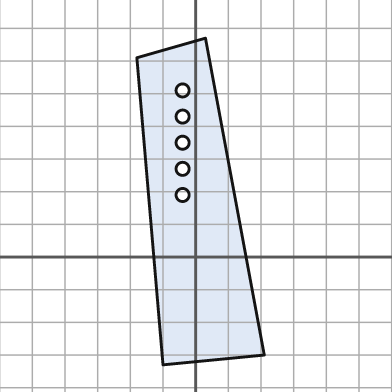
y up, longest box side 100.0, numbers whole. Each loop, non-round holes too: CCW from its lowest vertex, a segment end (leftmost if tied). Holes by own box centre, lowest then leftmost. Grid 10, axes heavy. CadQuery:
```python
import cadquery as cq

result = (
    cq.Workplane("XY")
    .moveTo(-10.0, -33.0)
    .lineTo(21.0, -30.0)
    .lineTo(3.0, 67.0)
    .lineTo(-18.0, 61.0)
    .close()
    .moveTo(-4.0, 19.0)
    .circle(2.0)
    .moveTo(-4.0, 27.0)
    .circle(2.0)
    .moveTo(-4.0, 35.0)
    .circle(2.0)
    .moveTo(-4.0, 43.0)
    .circle(2.0)
    .moveTo(-4.0, 51.0)
    .circle(2.0)
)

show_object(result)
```